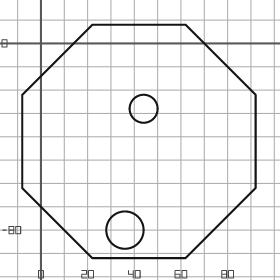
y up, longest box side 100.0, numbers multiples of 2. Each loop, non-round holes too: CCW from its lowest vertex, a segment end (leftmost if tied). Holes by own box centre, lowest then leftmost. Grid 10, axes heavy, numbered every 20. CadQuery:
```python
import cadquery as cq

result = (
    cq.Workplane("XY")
    .moveTo(22.0, -92.0)
    .lineTo(62.0, -92.0)
    .lineTo(92.0, -62.0)
    .lineTo(92.0, -22.0)
    .lineTo(62.0, 8.0)
    .lineTo(22.0, 8.0)
    .lineTo(-8.0, -22.0)
    .lineTo(-8.0, -62.0)
    .close()
    .moveTo(36.0, -80.0)
    .circle(8.0)
    .moveTo(44.0, -28.0)
    .circle(6.0)
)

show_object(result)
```